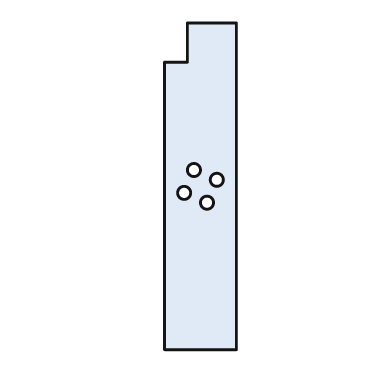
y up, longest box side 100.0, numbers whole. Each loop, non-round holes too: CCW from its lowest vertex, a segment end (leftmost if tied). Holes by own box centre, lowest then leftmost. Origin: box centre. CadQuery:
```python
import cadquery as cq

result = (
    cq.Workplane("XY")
    .moveTo(-11.0, -50.0)
    .lineTo(11.0, -50.0)
    .lineTo(11.0, 50.0)
    .lineTo(-4.0, 50.0)
    .lineTo(-4.0, 38.0)
    .lineTo(-11.0, 38.0)
    .close()
    .moveTo(2.0, -5.0)
    .circle(2.0)
    .moveTo(-5.0, -2.0)
    .circle(2.0)
    .moveTo(5.0, 2.0)
    .circle(2.0)
    .moveTo(-2.0, 5.0)
    .circle(2.0)
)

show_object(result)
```